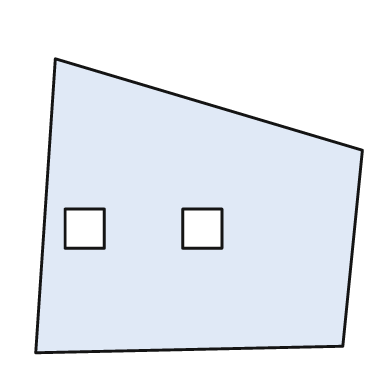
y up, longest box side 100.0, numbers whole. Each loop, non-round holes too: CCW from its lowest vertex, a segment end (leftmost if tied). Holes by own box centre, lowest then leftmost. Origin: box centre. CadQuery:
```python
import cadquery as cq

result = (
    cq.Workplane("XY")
    .moveTo(-50.0, -45.0)
    .lineTo(44.0, -43.0)
    .lineTo(50.0, 17.0)
    .lineTo(-44.0, 45.0)
    .close()
    .moveTo(-41.0, -13.0)
    .lineTo(-29.0, -13.0)
    .lineTo(-29.0, -1.0)
    .lineTo(-41.0, -1.0)
    .close()
    .moveTo(-5.0, -13.0)
    .lineTo(7.0, -13.0)
    .lineTo(7.0, -1.0)
    .lineTo(-5.0, -1.0)
    .close()
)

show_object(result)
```